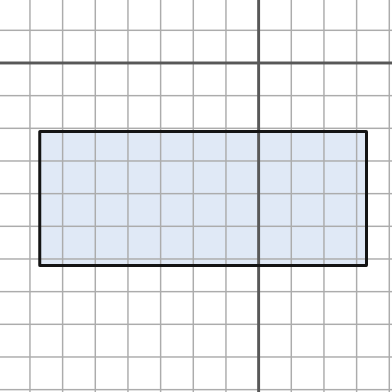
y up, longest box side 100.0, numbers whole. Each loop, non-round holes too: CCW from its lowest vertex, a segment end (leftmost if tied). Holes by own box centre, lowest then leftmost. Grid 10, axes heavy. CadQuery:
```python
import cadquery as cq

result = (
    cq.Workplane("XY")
    .moveTo(-67.0, -62.0)
    .lineTo(33.0, -62.0)
    .lineTo(33.0, -21.0)
    .lineTo(-67.0, -21.0)
    .close()
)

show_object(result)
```